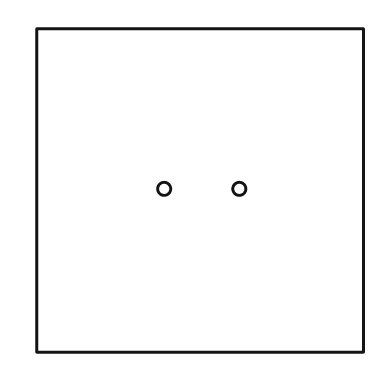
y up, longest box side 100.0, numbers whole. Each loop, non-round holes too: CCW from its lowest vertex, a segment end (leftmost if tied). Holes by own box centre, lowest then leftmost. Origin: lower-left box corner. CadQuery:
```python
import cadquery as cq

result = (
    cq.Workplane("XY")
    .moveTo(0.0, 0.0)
    .lineTo(100.0, 0.0)
    .lineTo(100.0, 99.0)
    .lineTo(0.0, 99.0)
    .close()
    .moveTo(39.0, 50.0)
    .circle(2.0)
    .moveTo(62.0, 50.0)
    .circle(2.0)
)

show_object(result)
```